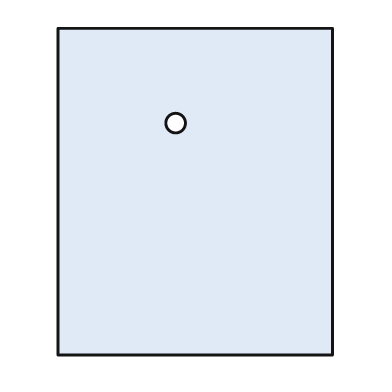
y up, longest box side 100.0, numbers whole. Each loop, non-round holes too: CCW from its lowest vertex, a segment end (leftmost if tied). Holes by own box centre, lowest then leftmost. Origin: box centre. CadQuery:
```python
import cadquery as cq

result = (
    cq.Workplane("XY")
    .moveTo(-42.0, -50.0)
    .lineTo(42.0, -50.0)
    .lineTo(42.0, 50.0)
    .lineTo(-42.0, 50.0)
    .close()
    .moveTo(-6.0, 21.0)
    .circle(3.0)
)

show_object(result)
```